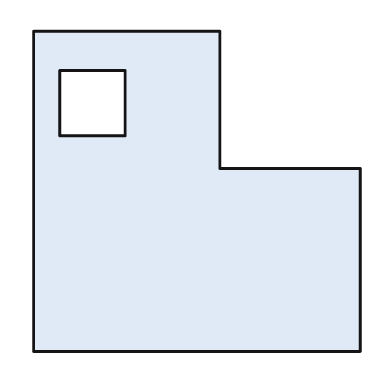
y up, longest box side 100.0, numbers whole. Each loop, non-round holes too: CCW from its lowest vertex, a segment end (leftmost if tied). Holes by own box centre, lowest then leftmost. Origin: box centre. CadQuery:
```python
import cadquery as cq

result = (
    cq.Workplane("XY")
    .moveTo(-50.0, -49.0)
    .lineTo(50.0, -49.0)
    .lineTo(50.0, 7.0)
    .lineTo(7.0, 7.0)
    .lineTo(7.0, 49.0)
    .lineTo(-50.0, 49.0)
    .close()
    .moveTo(-42.0, 17.0)
    .lineTo(-22.0, 17.0)
    .lineTo(-22.0, 37.0)
    .lineTo(-42.0, 37.0)
    .close()
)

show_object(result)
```